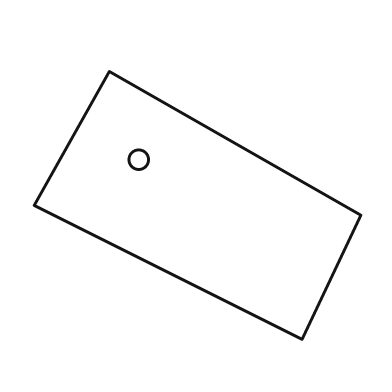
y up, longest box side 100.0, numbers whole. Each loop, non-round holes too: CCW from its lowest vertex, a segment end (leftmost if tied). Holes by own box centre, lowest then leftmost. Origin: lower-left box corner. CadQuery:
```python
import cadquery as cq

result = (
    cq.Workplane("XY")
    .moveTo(82.0, 0.0)
    .lineTo(100.0, 38.0)
    .lineTo(23.0, 82.0)
    .lineTo(0.0, 41.0)
    .close()
    .moveTo(32.0, 55.0)
    .circle(3.0)
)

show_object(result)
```